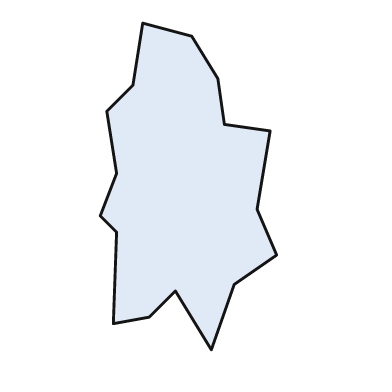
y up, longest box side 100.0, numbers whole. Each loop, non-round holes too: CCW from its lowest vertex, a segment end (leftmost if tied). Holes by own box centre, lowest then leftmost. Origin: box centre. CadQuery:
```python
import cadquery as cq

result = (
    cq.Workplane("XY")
    .moveTo(7.0, -50.0)
    .lineTo(14.0, -30.0)
    .lineTo(27.0, -21.0)
    .lineTo(21.0, -7.0)
    .lineTo(25.0, 17.0)
    .lineTo(11.0, 19.0)
    .lineTo(9.0, 33.0)
    .lineTo(1.0, 46.0)
    .lineTo(-14.0, 50.0)
    .lineTo(-17.0, 31.0)
    .lineTo(-25.0, 23.0)
    .lineTo(-22.0, 4.0)
    .lineTo(-27.0, -9.0)
    .lineTo(-22.0, -14.0)
    .lineTo(-23.0, -42.0)
    .lineTo(-12.0, -40.0)
    .lineTo(-4.0, -32.0)
    .close()
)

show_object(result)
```